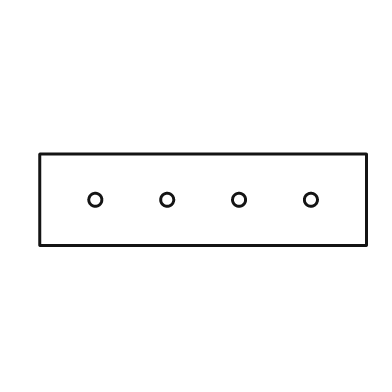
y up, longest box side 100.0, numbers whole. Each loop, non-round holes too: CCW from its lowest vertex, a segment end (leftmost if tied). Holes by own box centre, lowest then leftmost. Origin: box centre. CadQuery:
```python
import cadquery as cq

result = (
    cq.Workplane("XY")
    .moveTo(-50.0, -14.0)
    .lineTo(50.0, -14.0)
    .lineTo(50.0, 14.0)
    .lineTo(-50.0, 14.0)
    .close()
    .moveTo(-33.0, 0.0)
    .circle(2.0)
    .moveTo(-11.0, 0.0)
    .circle(2.0)
    .moveTo(11.0, 0.0)
    .circle(2.0)
    .moveTo(33.0, 0.0)
    .circle(2.0)
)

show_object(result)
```